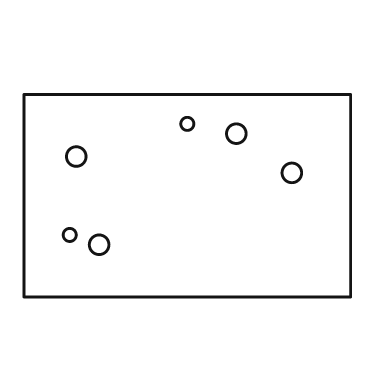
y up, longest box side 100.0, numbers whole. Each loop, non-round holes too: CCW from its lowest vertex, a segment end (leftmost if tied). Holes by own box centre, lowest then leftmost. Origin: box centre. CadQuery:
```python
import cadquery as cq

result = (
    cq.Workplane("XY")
    .moveTo(-50.0, -31.0)
    .lineTo(50.0, -31.0)
    .lineTo(50.0, 31.0)
    .lineTo(-50.0, 31.0)
    .close()
    .moveTo(-27.0, -15.0)
    .circle(3.0)
    .moveTo(-36.0, -12.0)
    .circle(2.0)
    .moveTo(32.0, 7.0)
    .circle(3.0)
    .moveTo(-34.0, 12.0)
    .circle(3.0)
    .moveTo(15.0, 19.0)
    .circle(3.0)
    .moveTo(0.0, 22.0)
    .circle(2.0)
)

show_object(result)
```